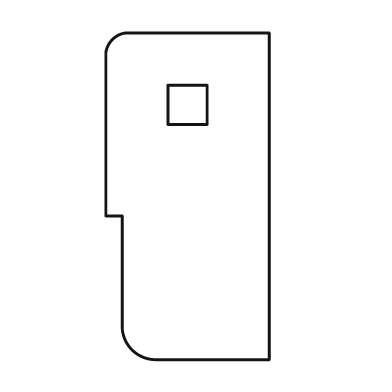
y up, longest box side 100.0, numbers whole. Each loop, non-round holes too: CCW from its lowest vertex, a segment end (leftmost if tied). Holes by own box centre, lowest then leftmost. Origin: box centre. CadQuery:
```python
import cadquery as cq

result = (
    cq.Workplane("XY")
    .moveTo(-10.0, -50.0)
    .lineTo(25.0, -50.0)
    .lineTo(25.0, 50.0)
    .lineTo(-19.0, 50.0)
    .threePointArc((-23.0, 48.0), (-25.0, 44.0))
    .lineTo(-25.0, -6.0)
    .lineTo(-20.0, -6.0)
    .lineTo(-20.0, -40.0)
    .threePointArc((-17.0, -47.0), (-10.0, -50.0))
    .close()
    .moveTo(-6.0, 22.0)
    .lineTo(6.0, 22.0)
    .lineTo(6.0, 34.0)
    .lineTo(-6.0, 34.0)
    .close()
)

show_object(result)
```